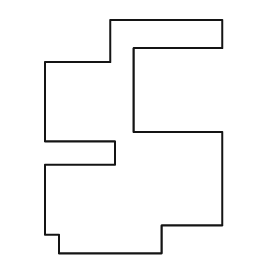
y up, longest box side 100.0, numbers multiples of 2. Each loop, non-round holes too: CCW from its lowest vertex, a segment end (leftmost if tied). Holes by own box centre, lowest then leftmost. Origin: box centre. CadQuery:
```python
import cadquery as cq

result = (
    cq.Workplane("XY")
    .moveTo(-32.0, -50.0)
    .lineTo(12.0, -50.0)
    .lineTo(12.0, -38.0)
    .lineTo(38.0, -38.0)
    .lineTo(38.0, 2.0)
    .lineTo(0.0, 2.0)
    .lineTo(0.0, 38.0)
    .lineTo(38.0, 38.0)
    .lineTo(38.0, 50.0)
    .lineTo(-10.0, 50.0)
    .lineTo(-10.0, 32.0)
    .lineTo(-38.0, 32.0)
    .lineTo(-38.0, -2.0)
    .lineTo(-8.0, -2.0)
    .lineTo(-8.0, -12.0)
    .lineTo(-38.0, -12.0)
    .lineTo(-38.0, -42.0)
    .lineTo(-32.0, -42.0)
    .close()
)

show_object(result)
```